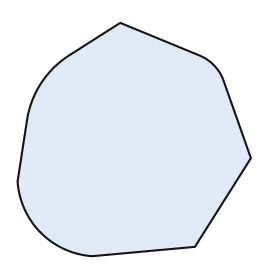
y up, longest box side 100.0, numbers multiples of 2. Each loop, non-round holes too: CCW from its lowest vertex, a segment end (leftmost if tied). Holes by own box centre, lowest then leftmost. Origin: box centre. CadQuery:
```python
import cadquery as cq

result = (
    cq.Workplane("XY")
    .moveTo(-18.0, -50.0)
    .lineTo(26.0, -46.0)
    .lineTo(50.0, -8.0)
    .lineTo(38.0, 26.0)
    .threePointArc((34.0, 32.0), (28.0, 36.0))
    .lineTo(-6.0, 50.0)
    .lineTo(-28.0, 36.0)
    .threePointArc((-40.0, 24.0), (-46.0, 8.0))
    .lineTo(-50.0, -18.0)
    .threePointArc((-40.0, -40.0), (-18.0, -50.0))
    .close()
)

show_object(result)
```